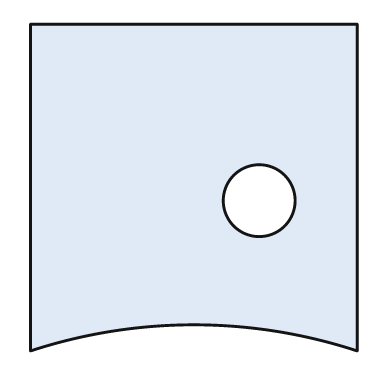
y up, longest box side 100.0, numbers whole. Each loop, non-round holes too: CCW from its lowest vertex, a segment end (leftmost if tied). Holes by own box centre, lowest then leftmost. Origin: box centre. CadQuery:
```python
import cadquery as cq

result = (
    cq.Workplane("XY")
    .moveTo(-50.0, -50.0)
    .threePointArc((0.0, -42.0), (50.0, -50.0))
    .lineTo(50.0, 50.0)
    .lineTo(-50.0, 50.0)
    .close()
    .moveTo(20.0, -4.0)
    .circle(11.0)
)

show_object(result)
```